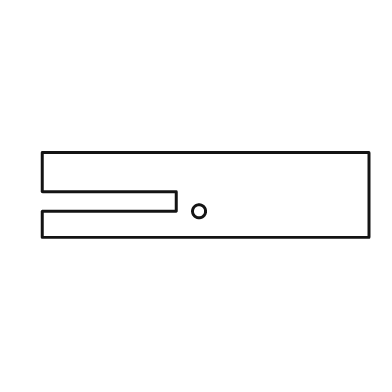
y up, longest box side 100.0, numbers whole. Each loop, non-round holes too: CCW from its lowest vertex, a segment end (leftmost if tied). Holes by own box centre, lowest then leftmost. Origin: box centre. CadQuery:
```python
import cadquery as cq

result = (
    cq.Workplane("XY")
    .moveTo(-50.0, -13.0)
    .lineTo(50.0, -13.0)
    .lineTo(50.0, 13.0)
    .lineTo(-50.0, 13.0)
    .lineTo(-50.0, 1.0)
    .lineTo(-9.0, 1.0)
    .lineTo(-9.0, -5.0)
    .lineTo(-50.0, -5.0)
    .close()
    .moveTo(-2.0, -5.0)
    .circle(2.0)
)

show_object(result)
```